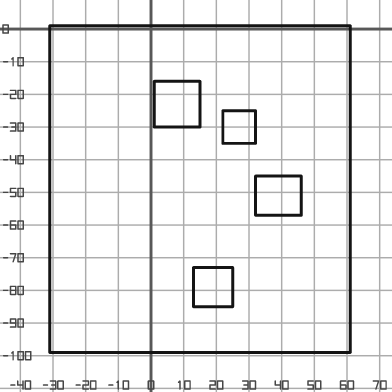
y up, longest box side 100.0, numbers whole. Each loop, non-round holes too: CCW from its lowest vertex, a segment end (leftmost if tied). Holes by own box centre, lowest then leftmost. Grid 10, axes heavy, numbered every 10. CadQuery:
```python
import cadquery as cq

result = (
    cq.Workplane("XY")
    .moveTo(-31.0, -99.0)
    .lineTo(61.0, -99.0)
    .lineTo(61.0, 1.0)
    .lineTo(-31.0, 1.0)
    .close()
    .moveTo(13.0, -85.0)
    .lineTo(25.0, -85.0)
    .lineTo(25.0, -73.0)
    .lineTo(13.0, -73.0)
    .close()
    .moveTo(32.0, -57.0)
    .lineTo(46.0, -57.0)
    .lineTo(46.0, -45.0)
    .lineTo(32.0, -45.0)
    .close()
    .moveTo(22.0, -35.0)
    .lineTo(32.0, -35.0)
    .lineTo(32.0, -25.0)
    .lineTo(22.0, -25.0)
    .close()
    .moveTo(1.0, -30.0)
    .lineTo(15.0, -30.0)
    .lineTo(15.0, -16.0)
    .lineTo(1.0, -16.0)
    .close()
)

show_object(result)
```